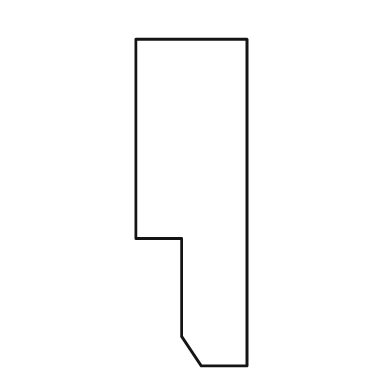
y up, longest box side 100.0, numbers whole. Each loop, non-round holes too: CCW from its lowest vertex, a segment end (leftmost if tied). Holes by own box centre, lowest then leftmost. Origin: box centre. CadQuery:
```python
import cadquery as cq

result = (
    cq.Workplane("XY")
    .moveTo(3.0, -50.0)
    .lineTo(17.0, -50.0)
    .lineTo(17.0, 50.0)
    .lineTo(-17.0, 50.0)
    .lineTo(-17.0, -11.0)
    .lineTo(-3.0, -11.0)
    .lineTo(-3.0, -41.0)
    .close()
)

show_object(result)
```